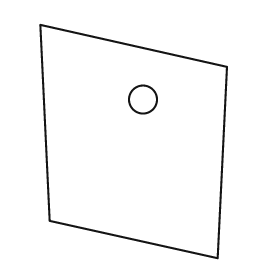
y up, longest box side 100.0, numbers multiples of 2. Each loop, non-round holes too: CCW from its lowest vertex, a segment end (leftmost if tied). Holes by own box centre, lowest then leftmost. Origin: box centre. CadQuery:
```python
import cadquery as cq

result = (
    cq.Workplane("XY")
    .moveTo(36.0, -50.0)
    .lineTo(40.0, 32.0)
    .lineTo(-40.0, 50.0)
    .lineTo(-36.0, -34.0)
    .close()
    .moveTo(4.0, 18.0)
    .circle(6.0)
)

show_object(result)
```